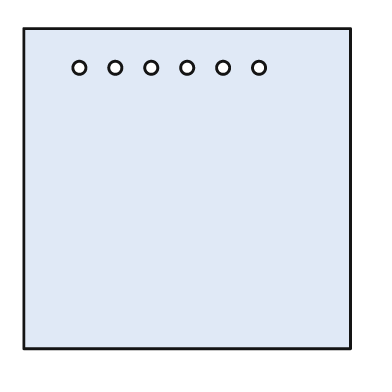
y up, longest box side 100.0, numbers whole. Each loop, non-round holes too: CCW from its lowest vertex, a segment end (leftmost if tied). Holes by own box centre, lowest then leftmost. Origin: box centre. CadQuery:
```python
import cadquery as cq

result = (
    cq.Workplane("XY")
    .moveTo(-50.0, -49.0)
    .lineTo(50.0, -49.0)
    .lineTo(50.0, 49.0)
    .lineTo(-50.0, 49.0)
    .close()
    .moveTo(-33.0, 37.0)
    .circle(2.0)
    .moveTo(-22.0, 37.0)
    .circle(2.0)
    .moveTo(-11.0, 37.0)
    .circle(2.0)
    .moveTo(0.0, 37.0)
    .circle(2.0)
    .moveTo(11.0, 37.0)
    .circle(2.0)
    .moveTo(22.0, 37.0)
    .circle(2.0)
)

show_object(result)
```